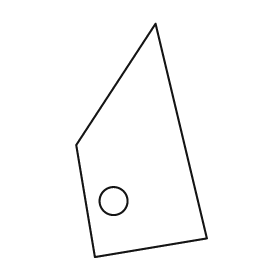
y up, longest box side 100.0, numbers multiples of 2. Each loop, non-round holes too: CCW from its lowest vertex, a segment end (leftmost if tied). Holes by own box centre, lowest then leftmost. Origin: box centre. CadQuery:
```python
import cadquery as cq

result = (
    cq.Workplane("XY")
    .moveTo(-20.0, -50.0)
    .lineTo(28.0, -42.0)
    .lineTo(6.0, 50.0)
    .lineTo(-28.0, -2.0)
    .close()
    .moveTo(-12.0, -26.0)
    .circle(6.0)
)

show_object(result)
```